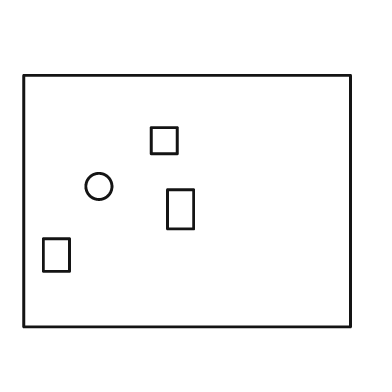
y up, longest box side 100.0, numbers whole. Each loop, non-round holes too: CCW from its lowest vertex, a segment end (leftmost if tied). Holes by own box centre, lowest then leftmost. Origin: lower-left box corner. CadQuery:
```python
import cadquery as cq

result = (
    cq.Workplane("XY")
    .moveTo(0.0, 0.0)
    .lineTo(100.0, 0.0)
    .lineTo(100.0, 77.0)
    .lineTo(0.0, 77.0)
    .close()
    .moveTo(6.0, 17.0)
    .lineTo(14.0, 17.0)
    .lineTo(14.0, 27.0)
    .lineTo(6.0, 27.0)
    .close()
    .moveTo(44.0, 30.0)
    .lineTo(52.0, 30.0)
    .lineTo(52.0, 42.0)
    .lineTo(44.0, 42.0)
    .close()
    .moveTo(23.0, 43.0)
    .circle(4.0)
    .moveTo(39.0, 53.0)
    .lineTo(47.0, 53.0)
    .lineTo(47.0, 61.0)
    .lineTo(39.0, 61.0)
    .close()
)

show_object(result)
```